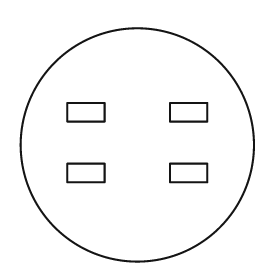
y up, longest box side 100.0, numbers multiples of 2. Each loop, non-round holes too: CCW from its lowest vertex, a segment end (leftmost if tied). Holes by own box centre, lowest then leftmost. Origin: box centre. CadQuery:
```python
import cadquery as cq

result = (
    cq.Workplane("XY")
    .moveTo(0.0, 0.0)
    .circle(50.0)
    .moveTo(-30.0, -16.0)
    .lineTo(-14.0, -16.0)
    .lineTo(-14.0, -8.0)
    .lineTo(-30.0, -8.0)
    .close()
    .moveTo(14.0, -16.0)
    .lineTo(30.0, -16.0)
    .lineTo(30.0, -8.0)
    .lineTo(14.0, -8.0)
    .close()
    .moveTo(-30.0, 10.0)
    .lineTo(-14.0, 10.0)
    .lineTo(-14.0, 18.0)
    .lineTo(-30.0, 18.0)
    .close()
    .moveTo(14.0, 10.0)
    .lineTo(30.0, 10.0)
    .lineTo(30.0, 18.0)
    .lineTo(14.0, 18.0)
    .close()
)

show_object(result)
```